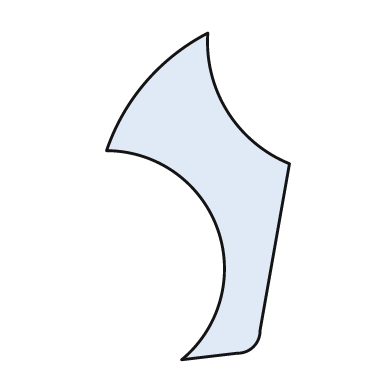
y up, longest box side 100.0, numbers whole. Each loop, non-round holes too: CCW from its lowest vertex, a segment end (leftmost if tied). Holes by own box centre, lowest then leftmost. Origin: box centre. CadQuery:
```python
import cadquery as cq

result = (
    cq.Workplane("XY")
    .moveTo(-5.0, -50.0)
    .lineTo(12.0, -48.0)
    .threePointArc((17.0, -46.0), (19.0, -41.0))
    .lineTo(28.0, 10.0)
    .threePointArc((9.0, 26.0), (3.0, 50.0))
    .threePointArc((-16.0, 35.0), (-28.0, 14.0))
    .threePointArc((6.0, -10.0), (-5.0, -50.0))
    .close()
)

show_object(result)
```